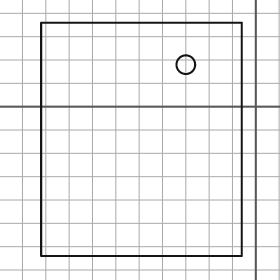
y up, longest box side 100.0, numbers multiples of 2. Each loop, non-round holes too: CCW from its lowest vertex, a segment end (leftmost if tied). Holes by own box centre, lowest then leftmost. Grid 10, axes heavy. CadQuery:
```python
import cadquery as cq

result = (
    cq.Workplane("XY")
    .moveTo(-92.0, -64.0)
    .lineTo(-6.0, -64.0)
    .lineTo(-6.0, 36.0)
    .lineTo(-92.0, 36.0)
    .close()
    .moveTo(-30.0, 18.0)
    .circle(4.0)
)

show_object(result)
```